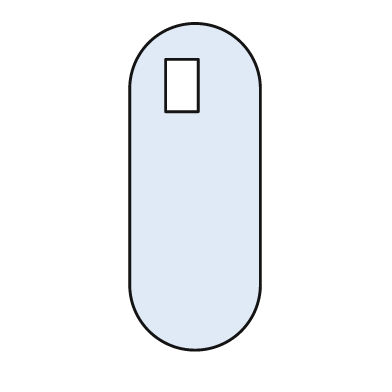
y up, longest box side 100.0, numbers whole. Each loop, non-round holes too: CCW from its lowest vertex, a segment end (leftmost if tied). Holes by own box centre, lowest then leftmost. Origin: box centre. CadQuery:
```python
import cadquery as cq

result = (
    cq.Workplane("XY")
    .moveTo(-20.0, -30.0)
    .threePointArc((0.0, -50.0), (20.0, -30.0))
    .lineTo(20.0, 30.0)
    .threePointArc((0.0, 50.0), (-20.0, 30.0))
    .close()
    .moveTo(-9.0, 23.0)
    .lineTo(1.0, 23.0)
    .lineTo(1.0, 39.0)
    .lineTo(-9.0, 39.0)
    .close()
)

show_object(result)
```